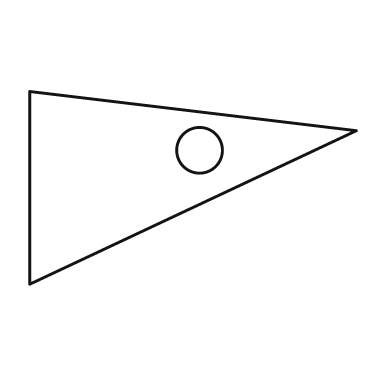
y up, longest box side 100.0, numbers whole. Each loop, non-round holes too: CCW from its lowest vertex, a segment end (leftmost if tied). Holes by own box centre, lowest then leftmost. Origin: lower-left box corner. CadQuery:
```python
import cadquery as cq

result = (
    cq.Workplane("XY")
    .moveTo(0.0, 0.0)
    .lineTo(100.0, 47.0)
    .lineTo(0.0, 59.0)
    .close()
    .moveTo(52.0, 41.0)
    .circle(7.0)
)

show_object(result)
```